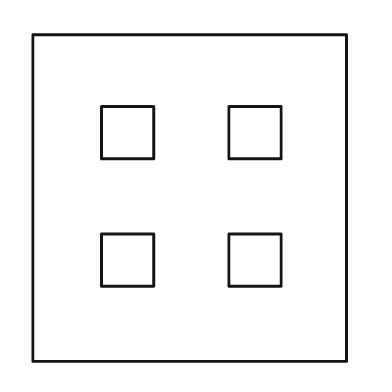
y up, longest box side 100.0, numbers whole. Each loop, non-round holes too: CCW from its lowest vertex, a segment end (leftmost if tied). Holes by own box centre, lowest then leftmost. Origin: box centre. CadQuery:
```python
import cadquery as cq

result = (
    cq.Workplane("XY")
    .moveTo(-48.0, -50.0)
    .lineTo(48.0, -50.0)
    .lineTo(48.0, 50.0)
    .lineTo(-48.0, 50.0)
    .close()
    .moveTo(-27.0, -27.0)
    .lineTo(-11.0, -27.0)
    .lineTo(-11.0, -11.0)
    .lineTo(-27.0, -11.0)
    .close()
    .moveTo(12.0, -27.0)
    .lineTo(28.0, -27.0)
    .lineTo(28.0, -11.0)
    .lineTo(12.0, -11.0)
    .close()
    .moveTo(-27.0, 12.0)
    .lineTo(-11.0, 12.0)
    .lineTo(-11.0, 28.0)
    .lineTo(-27.0, 28.0)
    .close()
    .moveTo(12.0, 12.0)
    .lineTo(28.0, 12.0)
    .lineTo(28.0, 28.0)
    .lineTo(12.0, 28.0)
    .close()
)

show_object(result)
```